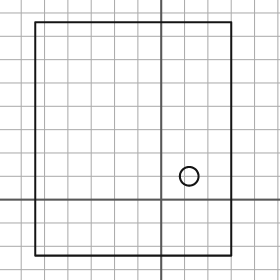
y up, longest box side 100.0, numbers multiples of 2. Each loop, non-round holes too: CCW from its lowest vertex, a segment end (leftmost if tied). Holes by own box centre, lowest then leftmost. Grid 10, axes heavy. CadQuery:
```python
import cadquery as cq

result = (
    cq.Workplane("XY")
    .moveTo(-54.0, -24.0)
    .lineTo(30.0, -24.0)
    .lineTo(30.0, 76.0)
    .lineTo(-54.0, 76.0)
    .close()
    .moveTo(12.0, 10.0)
    .circle(4.0)
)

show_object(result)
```